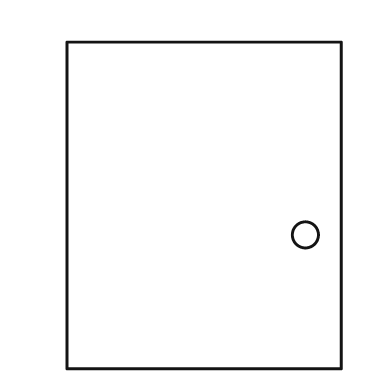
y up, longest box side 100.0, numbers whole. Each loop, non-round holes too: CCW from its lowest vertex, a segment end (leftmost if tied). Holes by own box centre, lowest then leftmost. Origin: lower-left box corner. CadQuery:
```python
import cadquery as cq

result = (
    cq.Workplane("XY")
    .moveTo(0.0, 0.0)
    .lineTo(84.0, 0.0)
    .lineTo(84.0, 100.0)
    .lineTo(0.0, 100.0)
    .close()
    .moveTo(73.0, 41.0)
    .circle(4.0)
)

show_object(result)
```